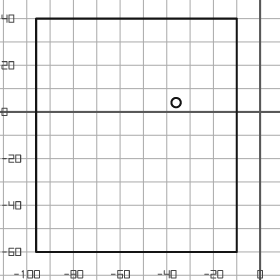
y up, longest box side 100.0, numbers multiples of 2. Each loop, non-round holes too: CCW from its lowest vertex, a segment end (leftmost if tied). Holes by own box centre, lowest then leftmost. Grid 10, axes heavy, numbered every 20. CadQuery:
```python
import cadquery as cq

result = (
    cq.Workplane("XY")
    .moveTo(-96.0, -60.0)
    .lineTo(-10.0, -60.0)
    .lineTo(-10.0, 40.0)
    .lineTo(-96.0, 40.0)
    .close()
    .moveTo(-36.0, 4.0)
    .circle(2.0)
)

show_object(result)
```